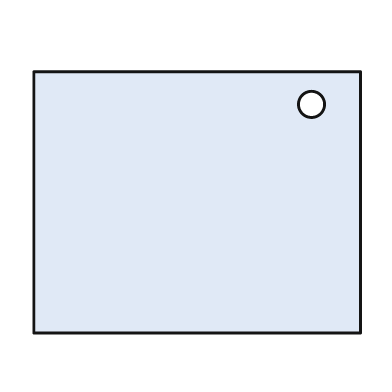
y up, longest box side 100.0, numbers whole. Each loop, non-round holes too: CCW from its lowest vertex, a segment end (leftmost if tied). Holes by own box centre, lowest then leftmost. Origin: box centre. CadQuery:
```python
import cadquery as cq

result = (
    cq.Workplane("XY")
    .moveTo(-50.0, -40.0)
    .lineTo(50.0, -40.0)
    .lineTo(50.0, 40.0)
    .lineTo(-50.0, 40.0)
    .close()
    .moveTo(35.0, 30.0)
    .circle(4.0)
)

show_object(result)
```